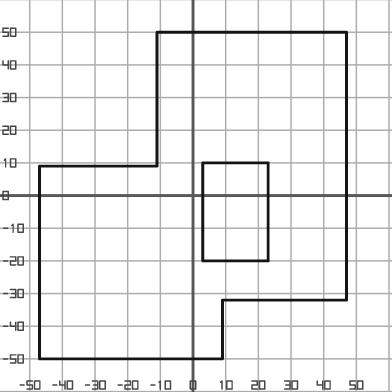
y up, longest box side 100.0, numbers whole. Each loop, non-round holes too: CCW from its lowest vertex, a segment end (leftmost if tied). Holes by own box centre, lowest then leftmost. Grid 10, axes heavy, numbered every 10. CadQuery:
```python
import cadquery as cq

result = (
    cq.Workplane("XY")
    .moveTo(-47.0, -50.0)
    .lineTo(9.0, -50.0)
    .lineTo(9.0, -32.0)
    .lineTo(47.0, -32.0)
    .lineTo(47.0, 50.0)
    .lineTo(-11.0, 50.0)
    .lineTo(-11.0, 9.0)
    .lineTo(-47.0, 9.0)
    .close()
    .moveTo(3.0, -20.0)
    .lineTo(23.0, -20.0)
    .lineTo(23.0, 10.0)
    .lineTo(3.0, 10.0)
    .close()
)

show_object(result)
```